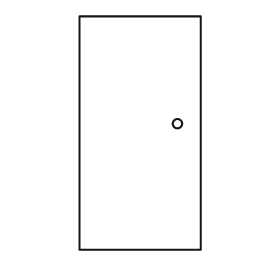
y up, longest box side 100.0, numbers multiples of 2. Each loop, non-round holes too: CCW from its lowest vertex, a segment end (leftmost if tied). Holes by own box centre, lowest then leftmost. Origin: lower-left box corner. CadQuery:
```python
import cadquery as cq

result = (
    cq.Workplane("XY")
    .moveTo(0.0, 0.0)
    .lineTo(52.0, 0.0)
    .lineTo(52.0, 100.0)
    .lineTo(0.0, 100.0)
    .close()
    .moveTo(42.0, 54.0)
    .circle(2.0)
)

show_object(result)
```